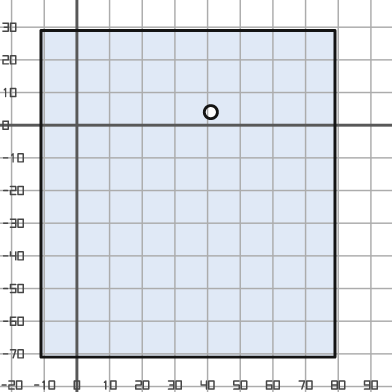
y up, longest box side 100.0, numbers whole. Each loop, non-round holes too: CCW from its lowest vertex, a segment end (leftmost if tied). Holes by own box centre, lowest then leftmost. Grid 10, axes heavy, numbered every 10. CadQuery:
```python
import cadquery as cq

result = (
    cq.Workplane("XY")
    .moveTo(-11.0, -71.0)
    .lineTo(79.0, -71.0)
    .lineTo(79.0, 29.0)
    .lineTo(-11.0, 29.0)
    .close()
    .moveTo(41.0, 4.0)
    .circle(2.0)
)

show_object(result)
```